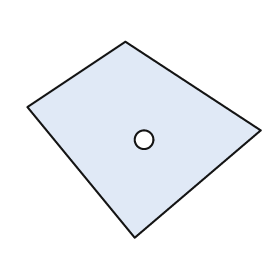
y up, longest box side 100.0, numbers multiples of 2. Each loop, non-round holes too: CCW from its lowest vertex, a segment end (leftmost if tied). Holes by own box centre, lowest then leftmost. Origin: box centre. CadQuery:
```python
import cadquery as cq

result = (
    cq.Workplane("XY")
    .moveTo(-4.0, -42.0)
    .lineTo(50.0, 4.0)
    .lineTo(-8.0, 42.0)
    .lineTo(-50.0, 14.0)
    .close()
    .moveTo(0.0, 0.0)
    .circle(4.0)
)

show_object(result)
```